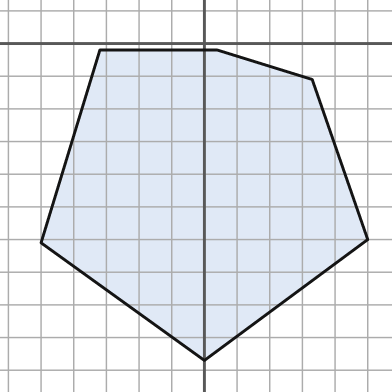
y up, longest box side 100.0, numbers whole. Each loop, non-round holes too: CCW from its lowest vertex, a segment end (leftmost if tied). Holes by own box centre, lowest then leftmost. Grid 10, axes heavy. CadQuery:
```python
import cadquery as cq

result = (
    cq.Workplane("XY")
    .moveTo(0.0, -97.0)
    .lineTo(50.0, -60.0)
    .lineTo(33.0, -11.0)
    .lineTo(4.0, -2.0)
    .lineTo(-32.0, -2.0)
    .lineTo(-50.0, -61.0)
    .close()
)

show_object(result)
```